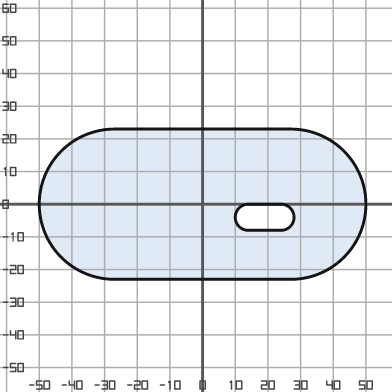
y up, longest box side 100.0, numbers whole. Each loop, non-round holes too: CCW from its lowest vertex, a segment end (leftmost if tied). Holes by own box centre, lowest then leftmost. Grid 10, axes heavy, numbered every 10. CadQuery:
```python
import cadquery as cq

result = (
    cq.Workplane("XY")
    .moveTo(-27.0, -23.0)
    .lineTo(27.0, -23.0)
    .threePointArc((50.0, 0.0), (27.0, 23.0))
    .lineTo(-27.0, 23.0)
    .threePointArc((-50.0, 0.0), (-27.0, -23.0))
    .close()
    .moveTo(14.0, -8.0)
    .lineTo(24.0, -8.0)
    .threePointArc((28.0, -4.0), (24.0, 0.0))
    .lineTo(14.0, 0.0)
    .threePointArc((10.0, -4.0), (14.0, -8.0))
    .close()
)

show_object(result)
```